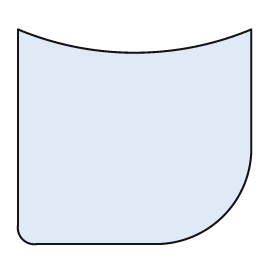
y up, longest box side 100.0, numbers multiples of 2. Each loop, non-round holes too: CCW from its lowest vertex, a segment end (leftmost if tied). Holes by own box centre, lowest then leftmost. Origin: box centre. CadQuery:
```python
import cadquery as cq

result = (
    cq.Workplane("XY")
    .moveTo(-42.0, -46.0)
    .lineTo(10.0, -46.0)
    .threePointArc((38.0, -34.0), (50.0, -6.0))
    .lineTo(50.0, 46.0)
    .threePointArc((0.0, 36.0), (-50.0, 46.0))
    .lineTo(-50.0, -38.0)
    .threePointArc((-48.0, -44.0), (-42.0, -46.0))
    .close()
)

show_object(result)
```